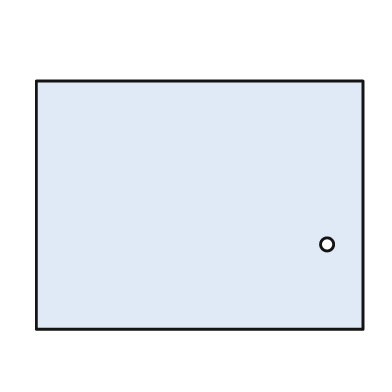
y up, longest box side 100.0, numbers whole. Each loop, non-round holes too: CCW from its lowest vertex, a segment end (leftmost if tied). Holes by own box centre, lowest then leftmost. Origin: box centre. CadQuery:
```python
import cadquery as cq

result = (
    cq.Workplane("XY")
    .moveTo(-50.0, -38.0)
    .lineTo(50.0, -38.0)
    .lineTo(50.0, 38.0)
    .lineTo(-50.0, 38.0)
    .close()
    .moveTo(39.0, -12.0)
    .circle(2.0)
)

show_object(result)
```